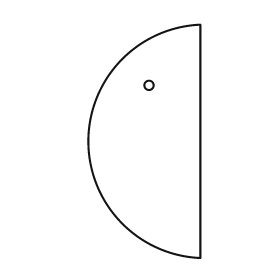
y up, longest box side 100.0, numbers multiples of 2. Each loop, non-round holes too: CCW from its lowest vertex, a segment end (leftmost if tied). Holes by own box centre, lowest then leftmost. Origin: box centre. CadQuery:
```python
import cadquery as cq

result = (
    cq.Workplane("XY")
    .moveTo(24.0, -50.0)
    .lineTo(24.0, 50.0)
    .threePointArc((-24.0, 0.0), (24.0, -50.0))
    .close()
    .moveTo(2.0, 24.0)
    .circle(2.0)
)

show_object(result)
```